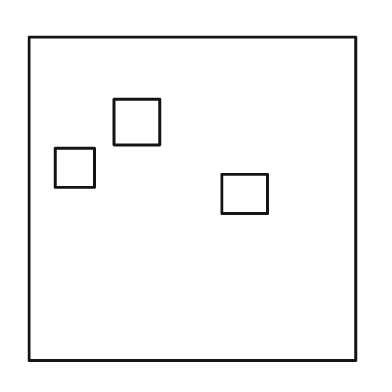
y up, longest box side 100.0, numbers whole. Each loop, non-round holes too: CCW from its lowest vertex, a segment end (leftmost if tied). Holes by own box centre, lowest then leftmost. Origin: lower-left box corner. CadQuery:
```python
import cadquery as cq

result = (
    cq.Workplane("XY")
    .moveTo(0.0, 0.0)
    .lineTo(100.0, 0.0)
    .lineTo(100.0, 99.0)
    .lineTo(0.0, 99.0)
    .close()
    .moveTo(59.0, 45.0)
    .lineTo(73.0, 45.0)
    .lineTo(73.0, 57.0)
    .lineTo(59.0, 57.0)
    .close()
    .moveTo(8.0, 53.0)
    .lineTo(20.0, 53.0)
    .lineTo(20.0, 65.0)
    .lineTo(8.0, 65.0)
    .close()
    .moveTo(26.0, 66.0)
    .lineTo(40.0, 66.0)
    .lineTo(40.0, 80.0)
    .lineTo(26.0, 80.0)
    .close()
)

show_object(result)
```